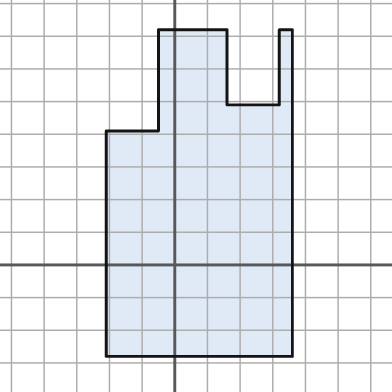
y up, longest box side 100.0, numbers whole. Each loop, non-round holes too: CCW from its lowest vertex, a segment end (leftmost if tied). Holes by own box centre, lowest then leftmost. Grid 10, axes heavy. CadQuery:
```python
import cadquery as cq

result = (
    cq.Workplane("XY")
    .moveTo(-21.0, -28.0)
    .lineTo(36.0, -28.0)
    .lineTo(36.0, 72.0)
    .lineTo(32.0, 72.0)
    .lineTo(32.0, 49.0)
    .lineTo(16.0, 49.0)
    .lineTo(16.0, 72.0)
    .lineTo(-5.0, 72.0)
    .lineTo(-5.0, 41.0)
    .lineTo(-21.0, 41.0)
    .close()
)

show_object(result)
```